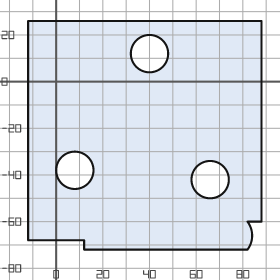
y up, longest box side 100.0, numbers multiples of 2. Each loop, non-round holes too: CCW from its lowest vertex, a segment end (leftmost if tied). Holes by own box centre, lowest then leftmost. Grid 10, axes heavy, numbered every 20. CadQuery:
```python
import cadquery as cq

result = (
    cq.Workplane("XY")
    .moveTo(12.0, -72.0)
    .lineTo(82.0, -72.0)
    .threePointArc((84.0, -66.0), (82.0, -60.0))
    .lineTo(88.0, -60.0)
    .lineTo(88.0, 26.0)
    .lineTo(-12.0, 26.0)
    .lineTo(-12.0, -68.0)
    .lineTo(12.0, -68.0)
    .close()
    .moveTo(66.0, -42.0)
    .circle(8.0)
    .moveTo(8.0, -38.0)
    .circle(8.0)
    .moveTo(40.0, 12.0)
    .circle(8.0)
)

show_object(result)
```